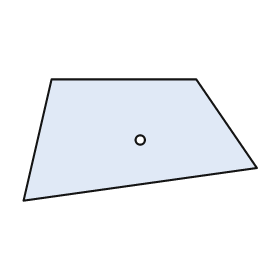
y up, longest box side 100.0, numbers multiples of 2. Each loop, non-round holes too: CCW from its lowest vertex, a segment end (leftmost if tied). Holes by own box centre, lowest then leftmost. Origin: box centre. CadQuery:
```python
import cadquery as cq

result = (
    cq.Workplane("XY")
    .moveTo(-50.0, -26.0)
    .lineTo(50.0, -12.0)
    .lineTo(24.0, 26.0)
    .lineTo(-38.0, 26.0)
    .close()
    .moveTo(0.0, 0.0)
    .circle(2.0)
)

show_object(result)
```